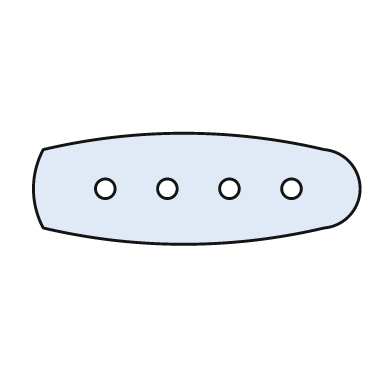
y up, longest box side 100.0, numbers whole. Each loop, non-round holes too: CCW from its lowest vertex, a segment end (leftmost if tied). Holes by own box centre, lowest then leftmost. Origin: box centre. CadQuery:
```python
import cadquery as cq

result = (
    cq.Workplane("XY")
    .moveTo(-47.0, -12.0)
    .threePointArc((-4.0, -17.0), (39.0, -12.0))
    .threePointArc((50.0, 0.0), (39.0, 12.0))
    .threePointArc((-4.0, 17.0), (-47.0, 12.0))
    .threePointArc((-50.0, 0.0), (-47.0, -12.0))
    .close()
    .moveTo(-28.0, 0.0)
    .circle(3.0)
    .moveTo(-9.0, 0.0)
    .circle(3.0)
    .moveTo(10.0, 0.0)
    .circle(3.0)
    .moveTo(29.0, 0.0)
    .circle(3.0)
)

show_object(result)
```